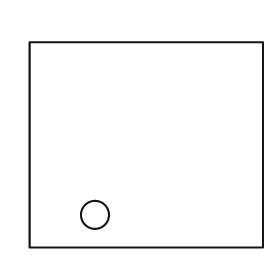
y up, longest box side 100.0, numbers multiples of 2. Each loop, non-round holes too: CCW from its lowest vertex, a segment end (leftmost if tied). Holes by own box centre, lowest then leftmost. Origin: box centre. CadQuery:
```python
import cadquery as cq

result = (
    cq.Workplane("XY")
    .moveTo(-50.0, -44.0)
    .lineTo(50.0, -44.0)
    .lineTo(50.0, 44.0)
    .lineTo(-50.0, 44.0)
    .close()
    .moveTo(-22.0, -30.0)
    .circle(6.0)
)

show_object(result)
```